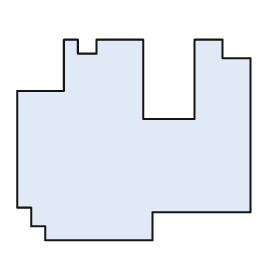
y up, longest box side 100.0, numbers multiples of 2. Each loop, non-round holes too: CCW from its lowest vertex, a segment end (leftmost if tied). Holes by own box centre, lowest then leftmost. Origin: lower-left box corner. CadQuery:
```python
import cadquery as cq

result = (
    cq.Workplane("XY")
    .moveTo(12.0, 0.0)
    .lineTo(58.0, 0.0)
    .lineTo(58.0, 12.0)
    .lineTo(100.0, 12.0)
    .lineTo(100.0, 78.0)
    .lineTo(88.0, 78.0)
    .lineTo(88.0, 86.0)
    .lineTo(76.0, 86.0)
    .lineTo(76.0, 52.0)
    .lineTo(54.0, 52.0)
    .lineTo(54.0, 86.0)
    .lineTo(34.0, 86.0)
    .lineTo(34.0, 80.0)
    .lineTo(26.0, 80.0)
    .lineTo(26.0, 86.0)
    .lineTo(20.0, 86.0)
    .lineTo(20.0, 64.0)
    .lineTo(0.0, 64.0)
    .lineTo(0.0, 14.0)
    .lineTo(6.0, 14.0)
    .lineTo(6.0, 6.0)
    .lineTo(12.0, 6.0)
    .close()
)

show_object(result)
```